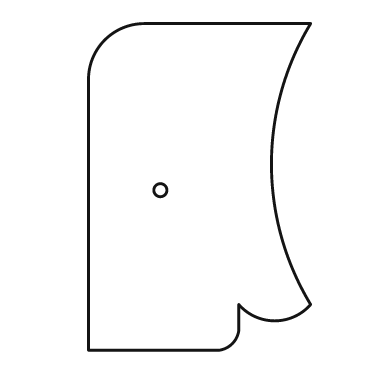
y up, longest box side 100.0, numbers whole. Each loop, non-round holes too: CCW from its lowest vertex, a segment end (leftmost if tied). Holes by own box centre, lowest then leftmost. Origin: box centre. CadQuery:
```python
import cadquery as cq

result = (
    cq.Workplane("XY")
    .moveTo(-34.0, -50.0)
    .lineTo(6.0, -50.0)
    .threePointArc((10.0, -48.0), (12.0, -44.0))
    .lineTo(12.0, -36.0)
    .threePointArc((23.0, -41.0), (34.0, -36.0))
    .threePointArc((22.0, 7.0), (34.0, 50.0))
    .lineTo(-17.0, 50.0)
    .threePointArc((-29.0, 45.0), (-34.0, 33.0))
    .close()
    .moveTo(-12.0, -1.0)
    .circle(2.0)
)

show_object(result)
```